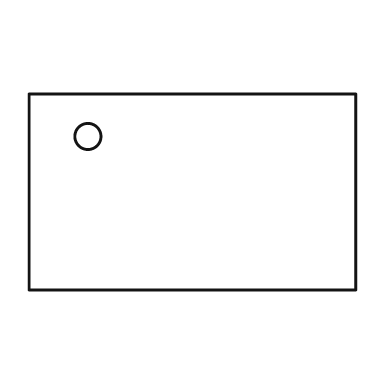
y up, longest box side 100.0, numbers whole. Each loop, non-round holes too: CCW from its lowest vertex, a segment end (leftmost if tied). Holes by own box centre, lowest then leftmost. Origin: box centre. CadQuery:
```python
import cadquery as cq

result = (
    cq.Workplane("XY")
    .moveTo(-50.0, -30.0)
    .lineTo(50.0, -30.0)
    .lineTo(50.0, 30.0)
    .lineTo(-50.0, 30.0)
    .close()
    .moveTo(-32.0, 17.0)
    .circle(4.0)
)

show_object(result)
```